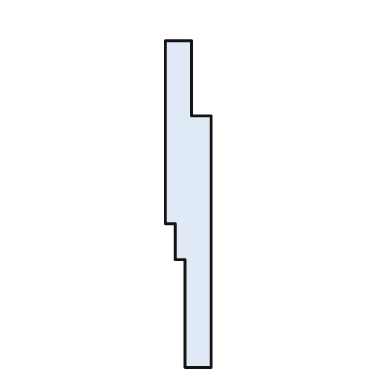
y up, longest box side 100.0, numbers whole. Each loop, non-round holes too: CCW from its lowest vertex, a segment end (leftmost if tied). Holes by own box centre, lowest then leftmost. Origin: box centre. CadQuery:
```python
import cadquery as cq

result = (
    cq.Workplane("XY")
    .moveTo(-1.0, -50.0)
    .lineTo(7.0, -50.0)
    .lineTo(7.0, 27.0)
    .lineTo(1.0, 27.0)
    .lineTo(1.0, 50.0)
    .lineTo(-7.0, 50.0)
    .lineTo(-7.0, -6.0)
    .lineTo(-4.0, -6.0)
    .lineTo(-4.0, -17.0)
    .lineTo(-1.0, -17.0)
    .close()
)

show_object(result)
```